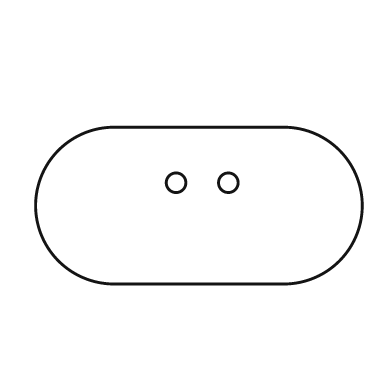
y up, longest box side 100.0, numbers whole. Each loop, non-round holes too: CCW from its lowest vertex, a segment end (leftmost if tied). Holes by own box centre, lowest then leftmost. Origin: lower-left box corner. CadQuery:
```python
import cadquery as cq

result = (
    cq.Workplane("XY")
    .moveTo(24.0, 0.0)
    .lineTo(76.0, 0.0)
    .threePointArc((100.0, 24.0), (76.0, 48.0))
    .lineTo(24.0, 48.0)
    .threePointArc((0.0, 24.0), (24.0, 0.0))
    .close()
    .moveTo(43.0, 31.0)
    .circle(3.0)
    .moveTo(59.0, 31.0)
    .circle(3.0)
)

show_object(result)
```